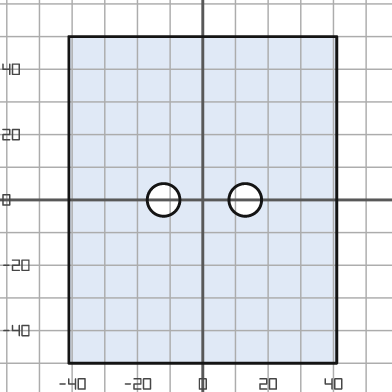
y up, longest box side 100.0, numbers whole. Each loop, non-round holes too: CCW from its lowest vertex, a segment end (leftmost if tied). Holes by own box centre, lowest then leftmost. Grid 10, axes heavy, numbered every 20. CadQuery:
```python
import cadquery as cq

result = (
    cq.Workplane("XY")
    .moveTo(-41.0, -50.0)
    .lineTo(41.0, -50.0)
    .lineTo(41.0, 50.0)
    .lineTo(-41.0, 50.0)
    .close()
    .moveTo(-12.0, 0.0)
    .circle(5.0)
    .moveTo(13.0, 0.0)
    .circle(5.0)
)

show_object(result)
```